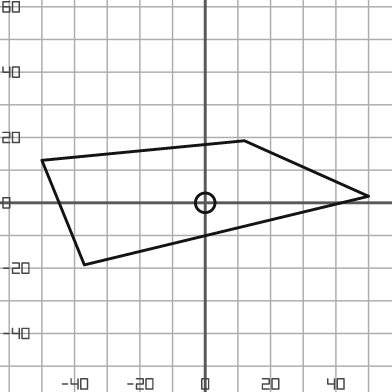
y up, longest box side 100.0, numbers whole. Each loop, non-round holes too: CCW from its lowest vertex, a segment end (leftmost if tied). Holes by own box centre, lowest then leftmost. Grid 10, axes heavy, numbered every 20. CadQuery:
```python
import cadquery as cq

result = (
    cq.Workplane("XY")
    .moveTo(-37.0, -19.0)
    .lineTo(50.0, 2.0)
    .lineTo(12.0, 19.0)
    .lineTo(-50.0, 13.0)
    .close()
    .moveTo(0.0, 0.0)
    .circle(3.0)
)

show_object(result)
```